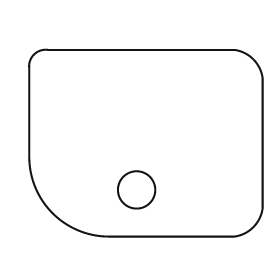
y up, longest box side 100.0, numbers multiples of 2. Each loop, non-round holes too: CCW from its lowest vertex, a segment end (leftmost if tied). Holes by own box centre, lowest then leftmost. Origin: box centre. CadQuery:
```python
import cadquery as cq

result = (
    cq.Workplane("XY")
    .moveTo(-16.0, -40.0)
    .lineTo(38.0, -40.0)
    .threePointArc((46.0, -36.0), (50.0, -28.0))
    .lineTo(50.0, 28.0)
    .threePointArc((46.0, 36.0), (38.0, 40.0))
    .lineTo(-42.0, 40.0)
    .threePointArc((-48.0, 38.0), (-50.0, 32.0))
    .lineTo(-50.0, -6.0)
    .threePointArc((-40.0, -30.0), (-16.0, -40.0))
    .close()
    .moveTo(-4.0, -20.0)
    .circle(8.0)
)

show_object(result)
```